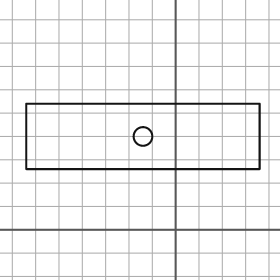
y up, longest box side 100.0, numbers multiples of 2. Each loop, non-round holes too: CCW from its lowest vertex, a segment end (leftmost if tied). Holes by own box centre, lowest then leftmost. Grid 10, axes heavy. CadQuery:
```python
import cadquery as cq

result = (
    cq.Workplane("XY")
    .moveTo(-64.0, 26.0)
    .lineTo(36.0, 26.0)
    .lineTo(36.0, 54.0)
    .lineTo(-64.0, 54.0)
    .close()
    .moveTo(-14.0, 40.0)
    .circle(4.0)
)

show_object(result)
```